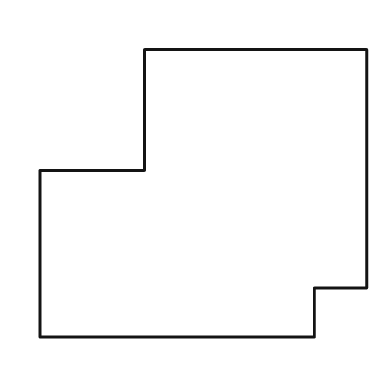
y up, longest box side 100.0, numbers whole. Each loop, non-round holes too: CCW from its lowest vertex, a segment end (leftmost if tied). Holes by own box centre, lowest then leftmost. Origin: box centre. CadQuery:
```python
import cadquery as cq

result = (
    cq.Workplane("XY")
    .moveTo(-50.0, -44.0)
    .lineTo(34.0, -44.0)
    .lineTo(34.0, -29.0)
    .lineTo(50.0, -29.0)
    .lineTo(50.0, 44.0)
    .lineTo(-18.0, 44.0)
    .lineTo(-18.0, 7.0)
    .lineTo(-50.0, 7.0)
    .close()
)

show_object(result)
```